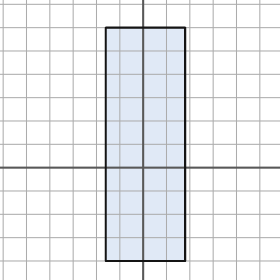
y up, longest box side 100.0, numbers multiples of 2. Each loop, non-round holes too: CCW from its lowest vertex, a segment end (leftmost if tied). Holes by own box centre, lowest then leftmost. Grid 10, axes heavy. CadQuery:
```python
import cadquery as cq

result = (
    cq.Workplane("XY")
    .moveTo(-16.0, -40.0)
    .lineTo(18.0, -40.0)
    .lineTo(18.0, 60.0)
    .lineTo(-16.0, 60.0)
    .close()
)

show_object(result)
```